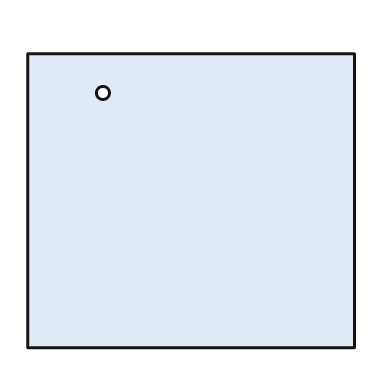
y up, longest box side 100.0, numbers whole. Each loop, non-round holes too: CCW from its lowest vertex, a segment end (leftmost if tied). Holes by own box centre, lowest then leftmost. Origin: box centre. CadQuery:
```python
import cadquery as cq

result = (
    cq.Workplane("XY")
    .moveTo(-50.0, -45.0)
    .lineTo(50.0, -45.0)
    .lineTo(50.0, 45.0)
    .lineTo(-50.0, 45.0)
    .close()
    .moveTo(-27.0, 33.0)
    .circle(2.0)
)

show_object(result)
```